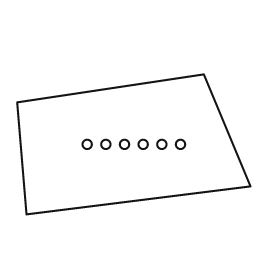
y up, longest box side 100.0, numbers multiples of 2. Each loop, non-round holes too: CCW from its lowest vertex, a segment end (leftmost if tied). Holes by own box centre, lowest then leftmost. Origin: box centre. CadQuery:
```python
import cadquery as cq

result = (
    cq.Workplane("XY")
    .moveTo(-46.0, -30.0)
    .lineTo(50.0, -18.0)
    .lineTo(30.0, 30.0)
    .lineTo(-50.0, 18.0)
    .close()
    .moveTo(-20.0, 0.0)
    .circle(2.0)
    .moveTo(-12.0, 0.0)
    .circle(2.0)
    .moveTo(-4.0, 0.0)
    .circle(2.0)
    .moveTo(4.0, 0.0)
    .circle(2.0)
    .moveTo(12.0, 0.0)
    .circle(2.0)
    .moveTo(20.0, 0.0)
    .circle(2.0)
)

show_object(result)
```